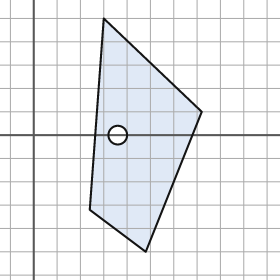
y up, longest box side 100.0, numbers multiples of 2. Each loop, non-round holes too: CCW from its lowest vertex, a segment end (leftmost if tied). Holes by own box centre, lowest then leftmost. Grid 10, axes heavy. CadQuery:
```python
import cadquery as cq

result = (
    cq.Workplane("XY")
    .moveTo(48.0, -50.0)
    .lineTo(72.0, 10.0)
    .lineTo(30.0, 50.0)
    .lineTo(24.0, -32.0)
    .close()
    .moveTo(36.0, 0.0)
    .circle(4.0)
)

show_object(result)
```